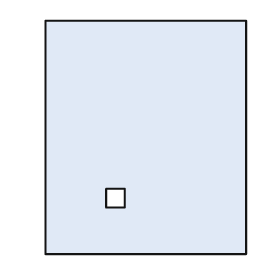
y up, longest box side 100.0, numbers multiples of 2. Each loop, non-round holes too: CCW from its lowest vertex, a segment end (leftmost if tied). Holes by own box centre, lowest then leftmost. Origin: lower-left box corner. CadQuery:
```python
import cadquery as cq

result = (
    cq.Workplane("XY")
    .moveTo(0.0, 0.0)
    .lineTo(86.0, 0.0)
    .lineTo(86.0, 100.0)
    .lineTo(0.0, 100.0)
    .close()
    .moveTo(26.0, 20.0)
    .lineTo(34.0, 20.0)
    .lineTo(34.0, 28.0)
    .lineTo(26.0, 28.0)
    .close()
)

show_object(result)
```